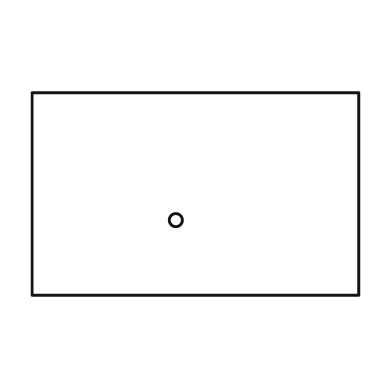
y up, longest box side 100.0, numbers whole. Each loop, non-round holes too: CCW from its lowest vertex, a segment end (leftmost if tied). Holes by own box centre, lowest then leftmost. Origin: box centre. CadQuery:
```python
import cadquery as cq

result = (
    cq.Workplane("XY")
    .moveTo(-50.0, -31.0)
    .lineTo(50.0, -31.0)
    .lineTo(50.0, 31.0)
    .lineTo(-50.0, 31.0)
    .close()
    .moveTo(-6.0, -8.0)
    .circle(2.0)
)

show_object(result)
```